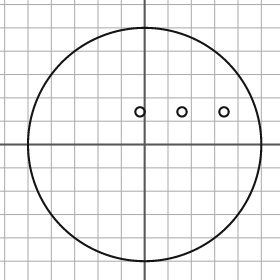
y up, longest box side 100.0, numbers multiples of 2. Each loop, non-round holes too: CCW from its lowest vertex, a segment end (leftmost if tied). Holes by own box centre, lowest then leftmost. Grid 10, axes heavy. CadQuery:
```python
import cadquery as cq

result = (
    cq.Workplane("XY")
    .moveTo(0.0, 0.0)
    .circle(50.0)
    .moveTo(-2.0, 14.0)
    .circle(2.0)
    .moveTo(16.0, 14.0)
    .circle(2.0)
    .moveTo(34.0, 14.0)
    .circle(2.0)
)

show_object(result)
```